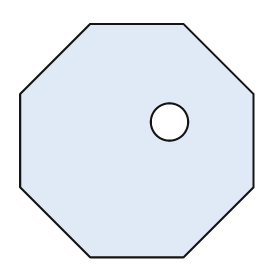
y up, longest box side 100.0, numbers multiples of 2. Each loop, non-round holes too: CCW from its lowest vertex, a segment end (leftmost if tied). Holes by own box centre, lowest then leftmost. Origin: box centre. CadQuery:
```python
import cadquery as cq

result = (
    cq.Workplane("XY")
    .moveTo(-20.0, -50.0)
    .lineTo(20.0, -50.0)
    .lineTo(50.0, -20.0)
    .lineTo(50.0, 20.0)
    .lineTo(20.0, 50.0)
    .lineTo(-20.0, 50.0)
    .lineTo(-50.0, 20.0)
    .lineTo(-50.0, -20.0)
    .close()
    .moveTo(14.0, 8.0)
    .circle(8.0)
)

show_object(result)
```